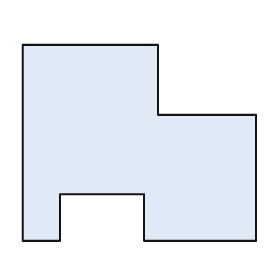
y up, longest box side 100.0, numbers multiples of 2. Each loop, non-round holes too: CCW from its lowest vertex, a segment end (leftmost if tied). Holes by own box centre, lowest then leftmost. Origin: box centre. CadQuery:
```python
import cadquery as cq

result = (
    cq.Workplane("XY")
    .moveTo(-50.0, -42.0)
    .lineTo(-34.0, -42.0)
    .lineTo(-34.0, -22.0)
    .lineTo(2.0, -22.0)
    .lineTo(2.0, -42.0)
    .lineTo(50.0, -42.0)
    .lineTo(50.0, 12.0)
    .lineTo(8.0, 12.0)
    .lineTo(8.0, 42.0)
    .lineTo(-50.0, 42.0)
    .close()
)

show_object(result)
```